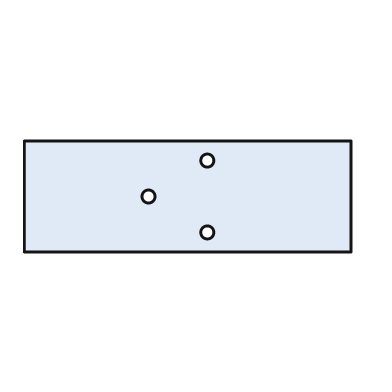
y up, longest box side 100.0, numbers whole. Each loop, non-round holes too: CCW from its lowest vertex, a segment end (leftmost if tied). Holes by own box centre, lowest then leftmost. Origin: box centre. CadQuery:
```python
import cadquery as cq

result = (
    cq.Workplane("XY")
    .moveTo(-50.0, -17.0)
    .lineTo(50.0, -17.0)
    .lineTo(50.0, 17.0)
    .lineTo(-50.0, 17.0)
    .close()
    .moveTo(6.0, -11.0)
    .circle(2.0)
    .moveTo(-12.0, 0.0)
    .circle(2.0)
    .moveTo(6.0, 11.0)
    .circle(2.0)
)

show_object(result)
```